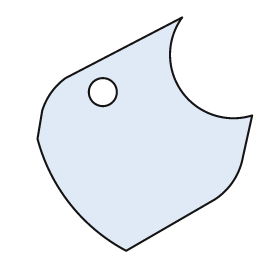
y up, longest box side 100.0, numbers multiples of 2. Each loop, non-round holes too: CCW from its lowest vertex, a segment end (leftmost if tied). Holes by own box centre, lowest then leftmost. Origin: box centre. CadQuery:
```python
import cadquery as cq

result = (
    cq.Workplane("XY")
    .moveTo(-8.0, -50.0)
    .lineTo(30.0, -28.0)
    .threePointArc((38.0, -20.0), (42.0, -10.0))
    .lineTo(46.0, 8.0)
    .threePointArc((16.0, 18.0), (16.0, 50.0))
    .lineTo(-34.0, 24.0)
    .threePointArc((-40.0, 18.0), (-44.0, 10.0))
    .lineTo(-46.0, -2.0)
    .threePointArc((-32.0, -30.0), (-8.0, -50.0))
    .close()
    .moveTo(-18.0, 18.0)
    .circle(6.0)
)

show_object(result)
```